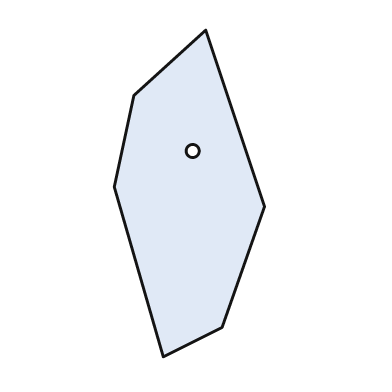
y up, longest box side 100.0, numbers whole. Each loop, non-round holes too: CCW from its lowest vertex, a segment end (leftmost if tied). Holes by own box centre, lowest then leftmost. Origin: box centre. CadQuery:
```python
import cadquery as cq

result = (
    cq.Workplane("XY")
    .moveTo(-8.0, -50.0)
    .lineTo(10.0, -41.0)
    .lineTo(23.0, -4.0)
    .lineTo(5.0, 50.0)
    .lineTo(-17.0, 30.0)
    .lineTo(-23.0, 2.0)
    .close()
    .moveTo(1.0, 13.0)
    .circle(2.0)
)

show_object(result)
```